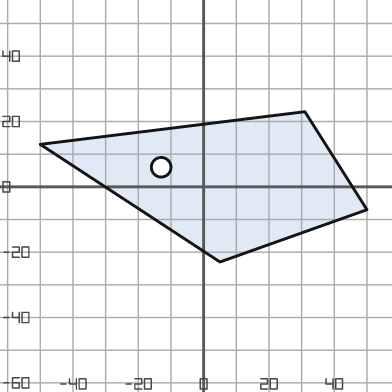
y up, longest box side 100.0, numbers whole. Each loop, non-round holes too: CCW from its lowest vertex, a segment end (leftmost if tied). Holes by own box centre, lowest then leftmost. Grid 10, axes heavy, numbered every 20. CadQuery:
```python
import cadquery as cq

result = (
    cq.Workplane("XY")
    .moveTo(5.0, -23.0)
    .lineTo(50.0, -7.0)
    .lineTo(31.0, 23.0)
    .lineTo(-50.0, 13.0)
    .close()
    .moveTo(-13.0, 6.0)
    .circle(3.0)
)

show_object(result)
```